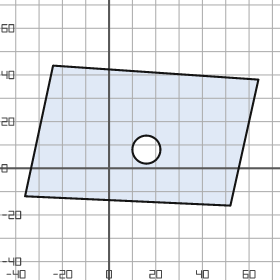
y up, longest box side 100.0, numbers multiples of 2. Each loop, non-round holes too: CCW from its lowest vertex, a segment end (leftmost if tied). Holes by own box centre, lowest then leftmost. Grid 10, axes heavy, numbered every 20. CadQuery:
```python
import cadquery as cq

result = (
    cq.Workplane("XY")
    .moveTo(52.0, -16.0)
    .lineTo(64.0, 38.0)
    .lineTo(-24.0, 44.0)
    .lineTo(-36.0, -12.0)
    .close()
    .moveTo(16.0, 8.0)
    .circle(6.0)
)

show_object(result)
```